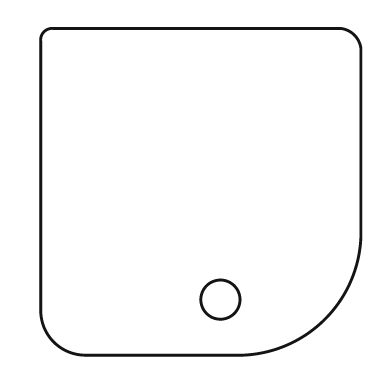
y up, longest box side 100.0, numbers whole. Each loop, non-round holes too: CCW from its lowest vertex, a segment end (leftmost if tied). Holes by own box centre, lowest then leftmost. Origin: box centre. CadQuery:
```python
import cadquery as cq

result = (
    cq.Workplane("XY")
    .moveTo(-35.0, -50.0)
    .lineTo(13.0, -50.0)
    .threePointArc((38.0, -39.0), (49.0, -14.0))
    .lineTo(49.0, 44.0)
    .threePointArc((47.0, 48.0), (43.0, 50.0))
    .lineTo(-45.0, 50.0)
    .threePointArc((-48.0, 49.0), (-49.0, 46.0))
    .lineTo(-49.0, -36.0)
    .threePointArc((-45.0, -46.0), (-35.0, -50.0))
    .close()
    .moveTo(6.0, -33.0)
    .circle(6.0)
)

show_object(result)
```